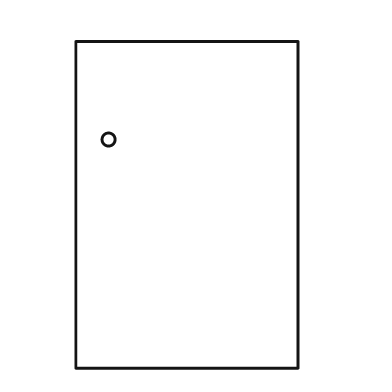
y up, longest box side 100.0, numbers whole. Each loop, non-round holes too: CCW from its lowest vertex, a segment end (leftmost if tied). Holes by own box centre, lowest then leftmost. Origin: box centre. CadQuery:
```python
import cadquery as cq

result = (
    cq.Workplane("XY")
    .moveTo(-34.0, -50.0)
    .lineTo(34.0, -50.0)
    .lineTo(34.0, 50.0)
    .lineTo(-34.0, 50.0)
    .close()
    .moveTo(-24.0, 20.0)
    .circle(2.0)
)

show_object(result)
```